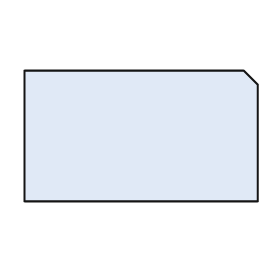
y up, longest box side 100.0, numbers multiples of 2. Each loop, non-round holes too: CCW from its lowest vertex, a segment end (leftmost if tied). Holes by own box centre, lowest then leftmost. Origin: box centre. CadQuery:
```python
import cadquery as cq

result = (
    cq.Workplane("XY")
    .moveTo(-50.0, -28.0)
    .lineTo(50.0, -28.0)
    .lineTo(50.0, 22.0)
    .lineTo(44.0, 28.0)
    .lineTo(-50.0, 28.0)
    .close()
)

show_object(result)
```